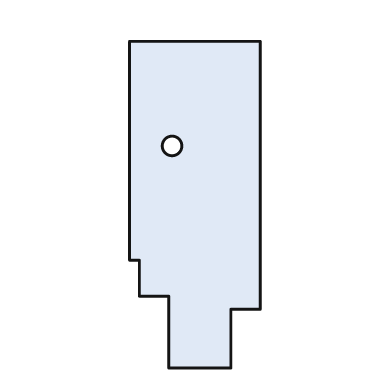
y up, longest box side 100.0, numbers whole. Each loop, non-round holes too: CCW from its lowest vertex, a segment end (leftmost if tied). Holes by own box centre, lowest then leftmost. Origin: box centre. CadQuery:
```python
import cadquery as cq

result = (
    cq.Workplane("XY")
    .moveTo(-8.0, -50.0)
    .lineTo(11.0, -50.0)
    .lineTo(11.0, -32.0)
    .lineTo(20.0, -32.0)
    .lineTo(20.0, 50.0)
    .lineTo(-20.0, 50.0)
    .lineTo(-20.0, -17.0)
    .lineTo(-17.0, -17.0)
    .lineTo(-17.0, -28.0)
    .lineTo(-8.0, -28.0)
    .close()
    .moveTo(-7.0, 18.0)
    .circle(3.0)
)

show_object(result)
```